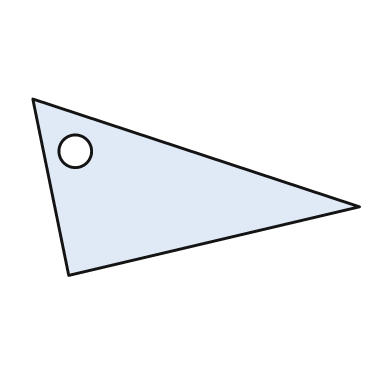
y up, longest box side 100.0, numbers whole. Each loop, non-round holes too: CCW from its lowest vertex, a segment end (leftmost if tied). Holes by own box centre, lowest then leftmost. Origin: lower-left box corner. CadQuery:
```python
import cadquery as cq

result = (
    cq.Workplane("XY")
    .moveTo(11.0, 0.0)
    .lineTo(100.0, 21.0)
    .lineTo(0.0, 54.0)
    .close()
    .moveTo(13.0, 38.0)
    .circle(5.0)
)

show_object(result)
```